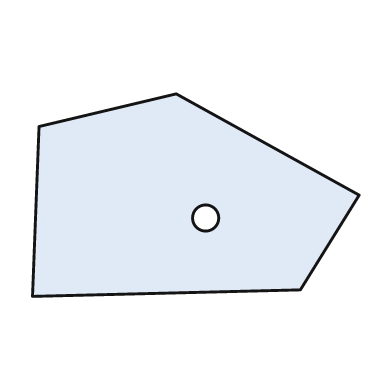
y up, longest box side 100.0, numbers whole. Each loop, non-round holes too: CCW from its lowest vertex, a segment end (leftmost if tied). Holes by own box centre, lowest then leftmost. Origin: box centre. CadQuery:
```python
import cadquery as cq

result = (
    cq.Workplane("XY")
    .moveTo(-50.0, -31.0)
    .lineTo(32.0, -29.0)
    .lineTo(50.0, 0.0)
    .lineTo(-6.0, 31.0)
    .lineTo(-48.0, 21.0)
    .close()
    .moveTo(3.0, -7.0)
    .circle(4.0)
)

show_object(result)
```